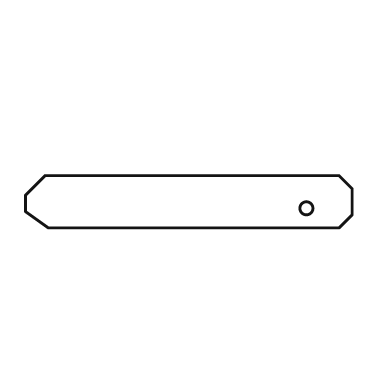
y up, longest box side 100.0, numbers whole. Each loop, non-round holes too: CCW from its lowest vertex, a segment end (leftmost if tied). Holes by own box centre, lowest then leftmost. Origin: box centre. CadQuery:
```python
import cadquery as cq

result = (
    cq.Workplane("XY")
    .moveTo(-43.0, -8.0)
    .lineTo(46.0, -8.0)
    .lineTo(50.0, -4.0)
    .lineTo(50.0, 4.0)
    .lineTo(46.0, 8.0)
    .lineTo(-44.0, 8.0)
    .lineTo(-50.0, 2.0)
    .lineTo(-50.0, -3.0)
    .close()
    .moveTo(36.0, -2.0)
    .circle(2.0)
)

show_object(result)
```